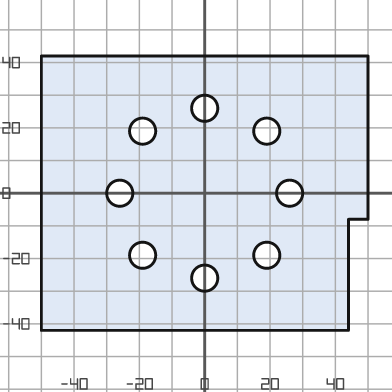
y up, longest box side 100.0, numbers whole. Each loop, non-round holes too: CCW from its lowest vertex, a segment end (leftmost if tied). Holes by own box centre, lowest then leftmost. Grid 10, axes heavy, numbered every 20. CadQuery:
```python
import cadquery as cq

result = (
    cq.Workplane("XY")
    .moveTo(-50.0, -42.0)
    .lineTo(44.0, -42.0)
    .lineTo(44.0, -8.0)
    .lineTo(50.0, -8.0)
    .lineTo(50.0, 42.0)
    .lineTo(-50.0, 42.0)
    .close()
    .moveTo(0.0, -26.0)
    .circle(4.0)
    .moveTo(-19.0, -19.0)
    .circle(4.0)
    .moveTo(19.0, -19.0)
    .circle(4.0)
    .moveTo(-26.0, 0.0)
    .circle(4.0)
    .moveTo(26.0, 0.0)
    .circle(4.0)
    .moveTo(-19.0, 19.0)
    .circle(4.0)
    .moveTo(19.0, 19.0)
    .circle(4.0)
    .moveTo(0.0, 26.0)
    .circle(4.0)
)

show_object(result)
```